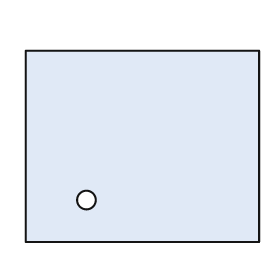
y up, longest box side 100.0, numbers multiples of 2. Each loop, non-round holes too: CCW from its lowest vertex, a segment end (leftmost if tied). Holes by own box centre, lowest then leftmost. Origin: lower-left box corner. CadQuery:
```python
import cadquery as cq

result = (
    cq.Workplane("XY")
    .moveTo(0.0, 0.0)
    .lineTo(100.0, 0.0)
    .lineTo(100.0, 82.0)
    .lineTo(0.0, 82.0)
    .close()
    .moveTo(26.0, 18.0)
    .circle(4.0)
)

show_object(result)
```